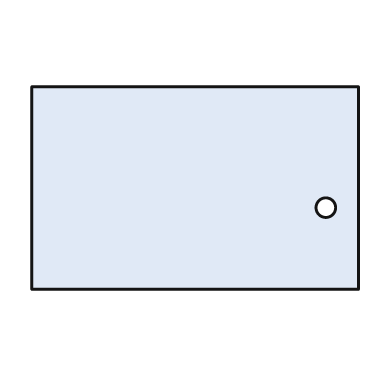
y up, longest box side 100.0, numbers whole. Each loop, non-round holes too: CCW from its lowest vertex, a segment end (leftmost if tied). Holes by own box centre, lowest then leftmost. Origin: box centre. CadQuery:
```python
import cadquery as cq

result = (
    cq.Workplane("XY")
    .moveTo(-50.0, -31.0)
    .lineTo(50.0, -31.0)
    .lineTo(50.0, 31.0)
    .lineTo(-50.0, 31.0)
    .close()
    .moveTo(40.0, -6.0)
    .circle(3.0)
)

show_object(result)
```